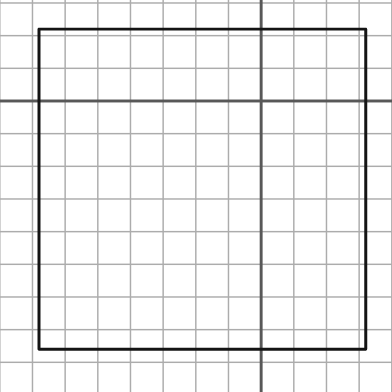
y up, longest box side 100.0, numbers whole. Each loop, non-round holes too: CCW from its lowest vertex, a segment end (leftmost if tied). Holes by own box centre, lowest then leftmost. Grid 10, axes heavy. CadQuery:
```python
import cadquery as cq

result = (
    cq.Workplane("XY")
    .moveTo(-68.0, -76.0)
    .lineTo(32.0, -76.0)
    .lineTo(32.0, 22.0)
    .lineTo(-68.0, 22.0)
    .close()
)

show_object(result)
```